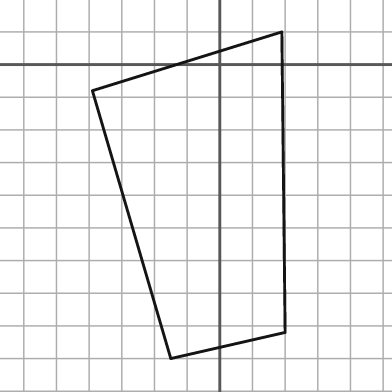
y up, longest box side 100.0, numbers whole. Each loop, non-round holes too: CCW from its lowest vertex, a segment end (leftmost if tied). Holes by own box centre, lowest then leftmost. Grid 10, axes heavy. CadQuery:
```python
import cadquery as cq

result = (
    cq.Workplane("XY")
    .moveTo(-15.0, -90.0)
    .lineTo(20.0, -82.0)
    .lineTo(19.0, 10.0)
    .lineTo(-39.0, -8.0)
    .close()
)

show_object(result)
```